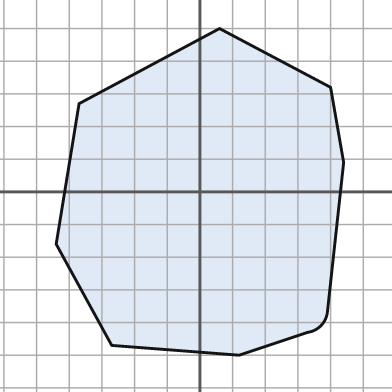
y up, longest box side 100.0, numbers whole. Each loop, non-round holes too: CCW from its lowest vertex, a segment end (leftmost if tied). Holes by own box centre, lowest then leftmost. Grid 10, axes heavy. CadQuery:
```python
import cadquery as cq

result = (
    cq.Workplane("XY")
    .moveTo(12.0, -50.0)
    .lineTo(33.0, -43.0)
    .threePointArc((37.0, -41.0), (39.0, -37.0))
    .lineTo(44.0, 9.0)
    .lineTo(40.0, 32.0)
    .lineTo(6.0, 50.0)
    .lineTo(-37.0, 27.0)
    .lineTo(-44.0, -16.0)
    .lineTo(-27.0, -47.0)
    .close()
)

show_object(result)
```